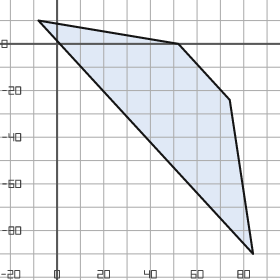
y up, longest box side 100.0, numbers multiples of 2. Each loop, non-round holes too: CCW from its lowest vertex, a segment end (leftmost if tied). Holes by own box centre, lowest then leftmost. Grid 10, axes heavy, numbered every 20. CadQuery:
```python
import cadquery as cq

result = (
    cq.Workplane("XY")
    .moveTo(84.0, -90.0)
    .lineTo(74.0, -24.0)
    .lineTo(52.0, 0.0)
    .lineTo(-8.0, 10.0)
    .close()
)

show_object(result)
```